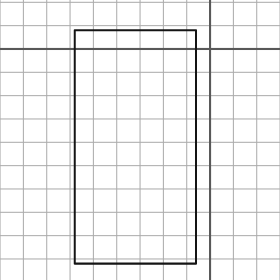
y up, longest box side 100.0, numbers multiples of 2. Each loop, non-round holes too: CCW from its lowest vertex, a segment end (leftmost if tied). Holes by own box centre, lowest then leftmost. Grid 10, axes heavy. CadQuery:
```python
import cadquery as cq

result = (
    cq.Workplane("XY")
    .moveTo(-58.0, -92.0)
    .lineTo(-6.0, -92.0)
    .lineTo(-6.0, 8.0)
    .lineTo(-58.0, 8.0)
    .close()
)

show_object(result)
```